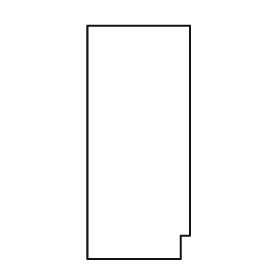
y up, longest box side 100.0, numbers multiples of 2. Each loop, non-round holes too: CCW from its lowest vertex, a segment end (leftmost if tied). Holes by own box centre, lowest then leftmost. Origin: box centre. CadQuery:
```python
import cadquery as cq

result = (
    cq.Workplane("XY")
    .moveTo(-22.0, -50.0)
    .lineTo(18.0, -50.0)
    .lineTo(18.0, -40.0)
    .lineTo(22.0, -40.0)
    .lineTo(22.0, 50.0)
    .lineTo(-22.0, 50.0)
    .close()
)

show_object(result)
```